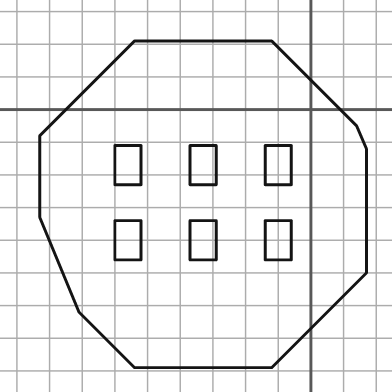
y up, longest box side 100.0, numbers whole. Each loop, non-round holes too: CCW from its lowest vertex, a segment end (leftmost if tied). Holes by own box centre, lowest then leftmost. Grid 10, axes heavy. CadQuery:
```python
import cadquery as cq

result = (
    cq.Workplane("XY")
    .moveTo(-54.0, -79.0)
    .lineTo(-12.0, -79.0)
    .lineTo(17.0, -50.0)
    .lineTo(17.0, -12.0)
    .lineTo(14.0, -5.0)
    .lineTo(-12.0, 21.0)
    .lineTo(-54.0, 21.0)
    .lineTo(-83.0, -8.0)
    .lineTo(-83.0, -33.0)
    .lineTo(-71.0, -62.0)
    .close()
    .moveTo(-60.0, -46.0)
    .lineTo(-52.0, -46.0)
    .lineTo(-52.0, -34.0)
    .lineTo(-60.0, -34.0)
    .close()
    .moveTo(-37.0, -46.0)
    .lineTo(-29.0, -46.0)
    .lineTo(-29.0, -34.0)
    .lineTo(-37.0, -34.0)
    .close()
    .moveTo(-14.0, -46.0)
    .lineTo(-6.0, -46.0)
    .lineTo(-6.0, -34.0)
    .lineTo(-14.0, -34.0)
    .close()
    .moveTo(-60.0, -23.0)
    .lineTo(-52.0, -23.0)
    .lineTo(-52.0, -11.0)
    .lineTo(-60.0, -11.0)
    .close()
    .moveTo(-37.0, -23.0)
    .lineTo(-29.0, -23.0)
    .lineTo(-29.0, -11.0)
    .lineTo(-37.0, -11.0)
    .close()
    .moveTo(-14.0, -23.0)
    .lineTo(-6.0, -23.0)
    .lineTo(-6.0, -11.0)
    .lineTo(-14.0, -11.0)
    .close()
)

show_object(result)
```